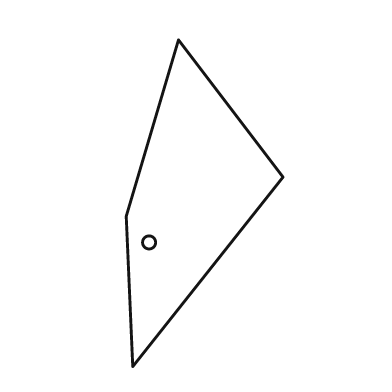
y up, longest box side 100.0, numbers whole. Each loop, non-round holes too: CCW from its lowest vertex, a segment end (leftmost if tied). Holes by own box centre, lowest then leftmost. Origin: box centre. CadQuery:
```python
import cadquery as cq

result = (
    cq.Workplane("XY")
    .moveTo(-22.0, -50.0)
    .lineTo(24.0, 8.0)
    .lineTo(-8.0, 50.0)
    .lineTo(-24.0, -4.0)
    .close()
    .moveTo(-17.0, -12.0)
    .circle(2.0)
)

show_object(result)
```